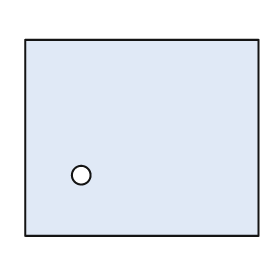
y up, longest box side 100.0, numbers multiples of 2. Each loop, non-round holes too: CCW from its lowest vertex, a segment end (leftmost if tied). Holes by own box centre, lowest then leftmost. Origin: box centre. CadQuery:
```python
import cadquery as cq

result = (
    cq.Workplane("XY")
    .moveTo(-50.0, -42.0)
    .lineTo(50.0, -42.0)
    .lineTo(50.0, 42.0)
    .lineTo(-50.0, 42.0)
    .close()
    .moveTo(-26.0, -16.0)
    .circle(4.0)
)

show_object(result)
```